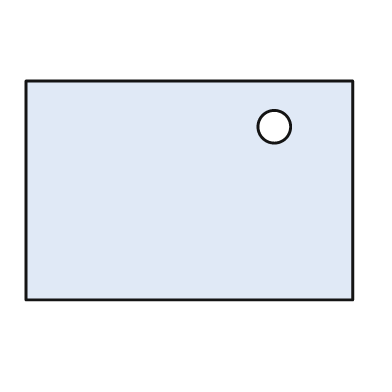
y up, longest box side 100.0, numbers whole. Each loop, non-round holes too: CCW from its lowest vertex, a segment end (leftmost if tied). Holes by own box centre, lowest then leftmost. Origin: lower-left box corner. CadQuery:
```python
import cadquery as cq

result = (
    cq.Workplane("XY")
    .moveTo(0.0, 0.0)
    .lineTo(100.0, 0.0)
    .lineTo(100.0, 67.0)
    .lineTo(0.0, 67.0)
    .close()
    .moveTo(76.0, 53.0)
    .circle(5.0)
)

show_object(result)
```